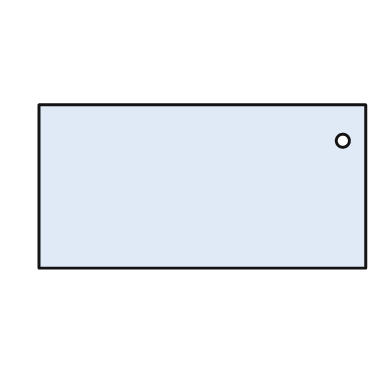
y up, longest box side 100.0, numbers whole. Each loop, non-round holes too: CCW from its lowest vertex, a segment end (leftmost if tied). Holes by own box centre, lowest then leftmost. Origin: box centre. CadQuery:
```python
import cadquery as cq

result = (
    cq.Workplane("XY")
    .moveTo(-50.0, -25.0)
    .lineTo(50.0, -25.0)
    .lineTo(50.0, 25.0)
    .lineTo(-50.0, 25.0)
    .close()
    .moveTo(43.0, 14.0)
    .circle(2.0)
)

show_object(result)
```